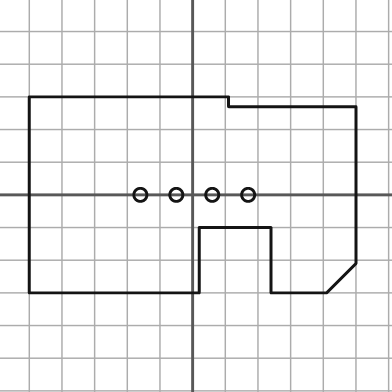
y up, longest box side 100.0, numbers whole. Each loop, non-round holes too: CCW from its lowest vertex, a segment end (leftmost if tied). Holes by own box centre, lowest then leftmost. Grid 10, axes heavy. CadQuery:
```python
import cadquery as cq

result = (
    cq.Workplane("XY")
    .moveTo(-50.0, -30.0)
    .lineTo(2.0, -30.0)
    .lineTo(2.0, -10.0)
    .lineTo(24.0, -10.0)
    .lineTo(24.0, -30.0)
    .lineTo(41.0, -30.0)
    .lineTo(50.0, -21.0)
    .lineTo(50.0, 27.0)
    .lineTo(11.0, 27.0)
    .lineTo(11.0, 30.0)
    .lineTo(-50.0, 30.0)
    .close()
    .moveTo(-16.0, 0.0)
    .circle(2.0)
    .moveTo(-5.0, 0.0)
    .circle(2.0)
    .moveTo(6.0, 0.0)
    .circle(2.0)
    .moveTo(17.0, 0.0)
    .circle(2.0)
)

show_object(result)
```